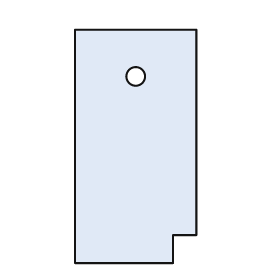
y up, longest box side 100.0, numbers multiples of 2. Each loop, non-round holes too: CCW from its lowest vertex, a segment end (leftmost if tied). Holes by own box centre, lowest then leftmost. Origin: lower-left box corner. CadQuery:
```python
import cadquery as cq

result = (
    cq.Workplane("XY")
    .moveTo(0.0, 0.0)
    .lineTo(42.0, 0.0)
    .lineTo(42.0, 12.0)
    .lineTo(52.0, 12.0)
    .lineTo(52.0, 100.0)
    .lineTo(0.0, 100.0)
    .close()
    .moveTo(26.0, 80.0)
    .circle(4.0)
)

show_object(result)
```